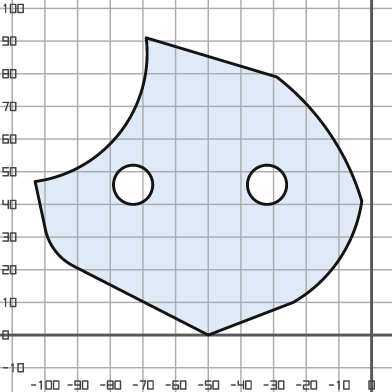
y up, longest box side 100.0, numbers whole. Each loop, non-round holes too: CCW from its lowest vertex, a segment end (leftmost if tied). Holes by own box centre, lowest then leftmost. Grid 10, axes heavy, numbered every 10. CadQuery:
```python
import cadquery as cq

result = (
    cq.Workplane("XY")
    .moveTo(-50.0, 0.0)
    .lineTo(-24.0, 10.0)
    .threePointArc((-10.0, 23.0), (-3.0, 41.0))
    .threePointArc((-13.0, 62.0), (-29.0, 79.0))
    .lineTo(-69.0, 91.0)
    .threePointArc((-77.0, 62.0), (-103.0, 47.0))
    .lineTo(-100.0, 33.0)
    .threePointArc((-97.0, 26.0), (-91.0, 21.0))
    .close()
    .moveTo(-73.0, 46.0)
    .circle(6.0)
    .moveTo(-32.0, 46.0)
    .circle(6.0)
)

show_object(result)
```